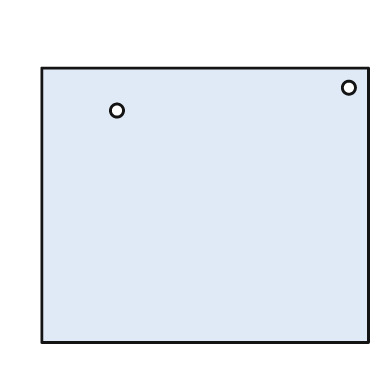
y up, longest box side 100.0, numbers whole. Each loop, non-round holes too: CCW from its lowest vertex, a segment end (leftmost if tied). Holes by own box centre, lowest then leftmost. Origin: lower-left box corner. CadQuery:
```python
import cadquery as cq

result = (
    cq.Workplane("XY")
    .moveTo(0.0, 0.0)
    .lineTo(100.0, 0.0)
    .lineTo(100.0, 84.0)
    .lineTo(0.0, 84.0)
    .close()
    .moveTo(23.0, 71.0)
    .circle(2.0)
    .moveTo(94.0, 78.0)
    .circle(2.0)
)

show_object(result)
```